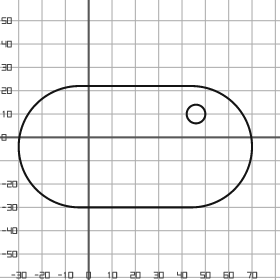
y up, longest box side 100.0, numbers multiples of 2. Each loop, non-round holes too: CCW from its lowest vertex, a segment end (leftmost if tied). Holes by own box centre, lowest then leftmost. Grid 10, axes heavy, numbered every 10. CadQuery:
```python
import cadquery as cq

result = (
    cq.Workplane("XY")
    .moveTo(-4.0, -30.0)
    .lineTo(44.0, -30.0)
    .threePointArc((70.0, -4.0), (44.0, 22.0))
    .lineTo(-4.0, 22.0)
    .threePointArc((-30.0, -4.0), (-4.0, -30.0))
    .close()
    .moveTo(46.0, 10.0)
    .circle(4.0)
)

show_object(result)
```